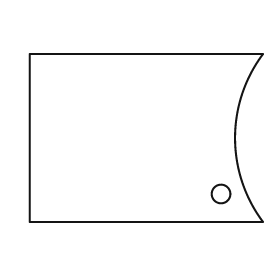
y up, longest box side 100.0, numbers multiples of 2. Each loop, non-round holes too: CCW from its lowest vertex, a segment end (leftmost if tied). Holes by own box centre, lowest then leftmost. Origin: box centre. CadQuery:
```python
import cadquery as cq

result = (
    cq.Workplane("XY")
    .moveTo(-50.0, -36.0)
    .lineTo(50.0, -36.0)
    .threePointArc((38.0, 0.0), (50.0, 36.0))
    .lineTo(-50.0, 36.0)
    .close()
    .moveTo(32.0, -24.0)
    .circle(4.0)
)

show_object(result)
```